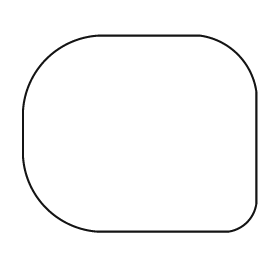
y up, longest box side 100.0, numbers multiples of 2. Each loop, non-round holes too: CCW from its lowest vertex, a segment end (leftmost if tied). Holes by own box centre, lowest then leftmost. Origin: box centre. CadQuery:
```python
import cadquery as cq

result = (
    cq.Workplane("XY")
    .moveTo(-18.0, -42.0)
    .lineTo(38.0, -42.0)
    .threePointArc((46.0, -38.0), (50.0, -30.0))
    .lineTo(50.0, 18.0)
    .threePointArc((42.0, 34.0), (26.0, 42.0))
    .lineTo(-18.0, 42.0)
    .threePointArc((-40.0, 32.0), (-50.0, 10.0))
    .lineTo(-50.0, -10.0)
    .threePointArc((-40.0, -32.0), (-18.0, -42.0))
    .close()
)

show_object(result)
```